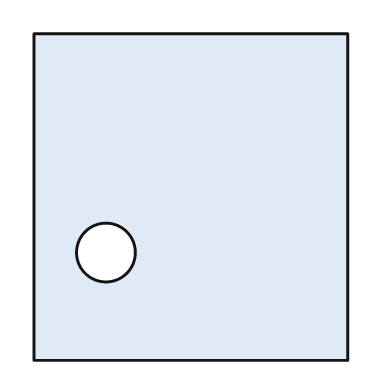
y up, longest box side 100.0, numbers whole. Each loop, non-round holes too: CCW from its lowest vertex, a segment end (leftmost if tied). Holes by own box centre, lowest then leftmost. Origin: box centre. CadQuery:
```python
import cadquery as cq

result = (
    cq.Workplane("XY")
    .moveTo(-48.0, -50.0)
    .lineTo(48.0, -50.0)
    .lineTo(48.0, 50.0)
    .lineTo(-48.0, 50.0)
    .close()
    .moveTo(-26.0, -17.0)
    .circle(9.0)
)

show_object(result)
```